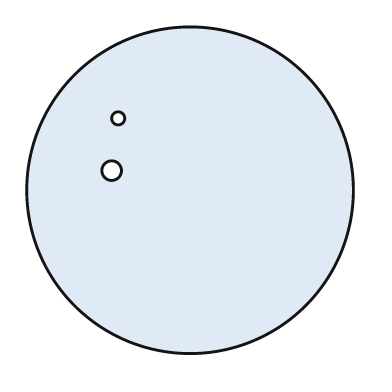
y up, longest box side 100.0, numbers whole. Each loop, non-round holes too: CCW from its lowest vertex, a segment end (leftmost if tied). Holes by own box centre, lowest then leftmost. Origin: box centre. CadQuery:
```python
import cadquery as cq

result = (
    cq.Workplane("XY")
    .moveTo(0.0, 0.0)
    .circle(50.0)
    .moveTo(-24.0, 6.0)
    .circle(3.0)
    .moveTo(-22.0, 22.0)
    .circle(2.0)
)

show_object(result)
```